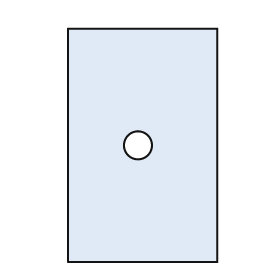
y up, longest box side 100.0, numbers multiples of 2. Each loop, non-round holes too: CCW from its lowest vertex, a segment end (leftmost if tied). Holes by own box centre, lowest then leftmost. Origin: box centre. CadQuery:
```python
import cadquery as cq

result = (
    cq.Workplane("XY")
    .moveTo(-32.0, -50.0)
    .lineTo(32.0, -50.0)
    .lineTo(32.0, 50.0)
    .lineTo(-32.0, 50.0)
    .close()
    .moveTo(-2.0, 0.0)
    .circle(6.0)
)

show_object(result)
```